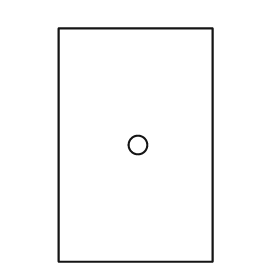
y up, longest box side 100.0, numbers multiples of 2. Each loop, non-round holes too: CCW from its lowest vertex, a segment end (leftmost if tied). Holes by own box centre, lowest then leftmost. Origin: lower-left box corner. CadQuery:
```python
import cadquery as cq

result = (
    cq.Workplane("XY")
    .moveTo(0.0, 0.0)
    .lineTo(66.0, 0.0)
    .lineTo(66.0, 100.0)
    .lineTo(0.0, 100.0)
    .close()
    .moveTo(34.0, 50.0)
    .circle(4.0)
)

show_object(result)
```